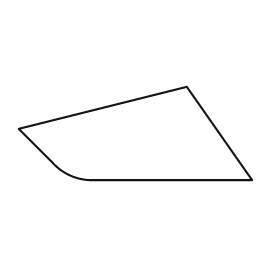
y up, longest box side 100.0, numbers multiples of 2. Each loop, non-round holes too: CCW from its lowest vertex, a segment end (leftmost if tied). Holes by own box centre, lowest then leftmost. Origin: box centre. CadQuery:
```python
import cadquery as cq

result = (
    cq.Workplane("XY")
    .moveTo(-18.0, -20.0)
    .lineTo(50.0, -20.0)
    .lineTo(22.0, 20.0)
    .lineTo(-50.0, 2.0)
    .lineTo(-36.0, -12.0)
    .threePointArc((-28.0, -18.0), (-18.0, -20.0))
    .close()
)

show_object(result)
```